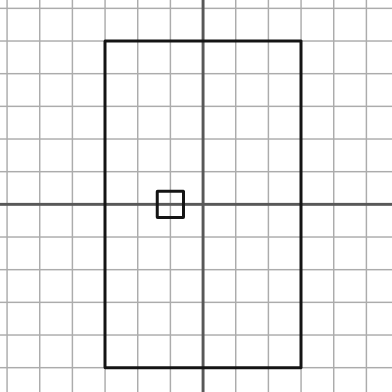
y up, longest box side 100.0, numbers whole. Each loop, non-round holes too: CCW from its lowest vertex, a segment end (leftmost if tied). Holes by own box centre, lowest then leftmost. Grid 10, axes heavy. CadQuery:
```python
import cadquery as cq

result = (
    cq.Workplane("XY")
    .moveTo(-30.0, -50.0)
    .lineTo(30.0, -50.0)
    .lineTo(30.0, 50.0)
    .lineTo(-30.0, 50.0)
    .close()
    .moveTo(-14.0, -4.0)
    .lineTo(-6.0, -4.0)
    .lineTo(-6.0, 4.0)
    .lineTo(-14.0, 4.0)
    .close()
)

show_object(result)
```